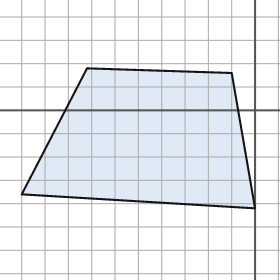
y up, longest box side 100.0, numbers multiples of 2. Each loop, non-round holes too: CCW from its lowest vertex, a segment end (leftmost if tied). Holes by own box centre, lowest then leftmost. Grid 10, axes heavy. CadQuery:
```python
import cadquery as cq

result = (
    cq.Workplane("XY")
    .moveTo(0.0, -42.0)
    .lineTo(-10.0, 16.0)
    .lineTo(-72.0, 18.0)
    .lineTo(-100.0, -36.0)
    .close()
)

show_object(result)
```